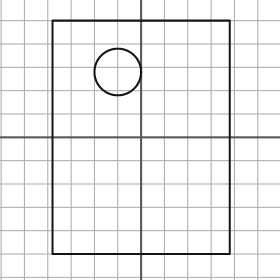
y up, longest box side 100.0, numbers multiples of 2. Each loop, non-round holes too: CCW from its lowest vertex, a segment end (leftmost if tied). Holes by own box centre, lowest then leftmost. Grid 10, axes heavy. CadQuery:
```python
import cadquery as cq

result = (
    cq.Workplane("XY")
    .moveTo(-38.0, -50.0)
    .lineTo(38.0, -50.0)
    .lineTo(38.0, 50.0)
    .lineTo(-38.0, 50.0)
    .close()
    .moveTo(-10.0, 28.0)
    .circle(10.0)
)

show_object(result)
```